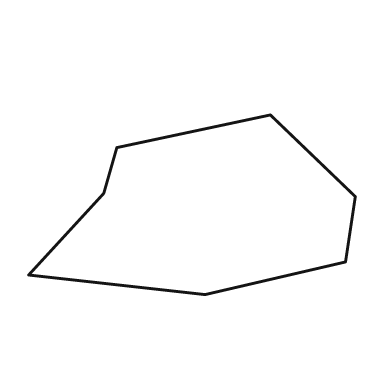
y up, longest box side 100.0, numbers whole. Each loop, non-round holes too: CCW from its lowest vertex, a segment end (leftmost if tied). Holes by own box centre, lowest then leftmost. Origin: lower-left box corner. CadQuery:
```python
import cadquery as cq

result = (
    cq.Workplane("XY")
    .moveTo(54.0, 0.0)
    .lineTo(97.0, 10.0)
    .lineTo(100.0, 30.0)
    .lineTo(74.0, 55.0)
    .lineTo(27.0, 45.0)
    .lineTo(23.0, 31.0)
    .lineTo(0.0, 6.0)
    .close()
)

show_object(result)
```